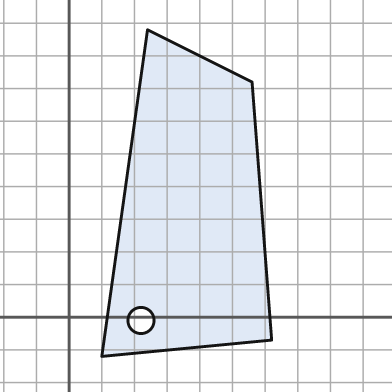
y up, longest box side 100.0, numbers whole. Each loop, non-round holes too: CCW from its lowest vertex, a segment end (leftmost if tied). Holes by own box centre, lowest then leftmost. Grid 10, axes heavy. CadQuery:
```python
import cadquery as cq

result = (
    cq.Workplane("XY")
    .moveTo(10.0, -12.0)
    .lineTo(62.0, -7.0)
    .lineTo(56.0, 72.0)
    .lineTo(24.0, 88.0)
    .close()
    .moveTo(22.0, -1.0)
    .circle(4.0)
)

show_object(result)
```